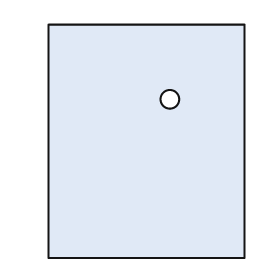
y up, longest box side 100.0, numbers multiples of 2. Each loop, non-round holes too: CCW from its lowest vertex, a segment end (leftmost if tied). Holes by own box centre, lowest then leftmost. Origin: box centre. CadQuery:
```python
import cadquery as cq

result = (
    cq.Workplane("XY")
    .moveTo(-42.0, -50.0)
    .lineTo(42.0, -50.0)
    .lineTo(42.0, 50.0)
    .lineTo(-42.0, 50.0)
    .close()
    .moveTo(10.0, 18.0)
    .circle(4.0)
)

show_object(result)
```